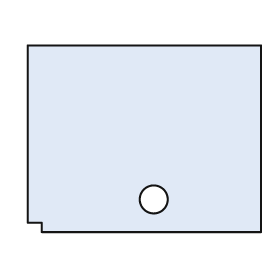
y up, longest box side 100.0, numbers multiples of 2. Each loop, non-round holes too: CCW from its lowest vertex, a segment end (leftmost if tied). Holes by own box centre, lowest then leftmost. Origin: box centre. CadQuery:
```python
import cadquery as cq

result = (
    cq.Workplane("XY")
    .moveTo(-44.0, -40.0)
    .lineTo(50.0, -40.0)
    .lineTo(50.0, 40.0)
    .lineTo(-50.0, 40.0)
    .lineTo(-50.0, -36.0)
    .lineTo(-44.0, -36.0)
    .close()
    .moveTo(4.0, -26.0)
    .circle(6.0)
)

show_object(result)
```